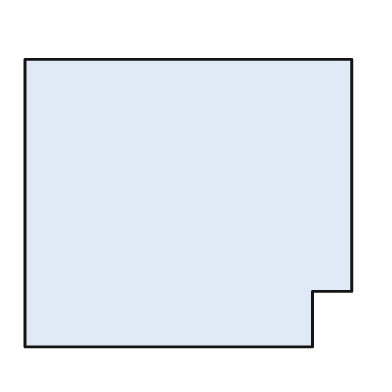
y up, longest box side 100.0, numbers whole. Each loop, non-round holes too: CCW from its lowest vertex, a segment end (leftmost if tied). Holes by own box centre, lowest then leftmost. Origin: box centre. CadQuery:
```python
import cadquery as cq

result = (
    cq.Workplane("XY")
    .moveTo(-50.0, -44.0)
    .lineTo(38.0, -44.0)
    .lineTo(38.0, -27.0)
    .lineTo(50.0, -27.0)
    .lineTo(50.0, 44.0)
    .lineTo(-50.0, 44.0)
    .close()
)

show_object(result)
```